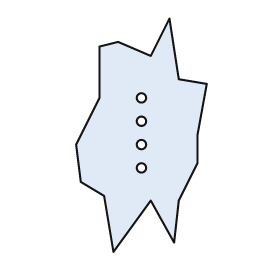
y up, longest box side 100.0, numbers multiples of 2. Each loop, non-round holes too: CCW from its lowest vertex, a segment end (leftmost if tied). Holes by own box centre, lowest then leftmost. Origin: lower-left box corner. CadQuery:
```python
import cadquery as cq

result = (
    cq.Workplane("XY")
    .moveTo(16.0, 0.0)
    .lineTo(32.0, 22.0)
    .lineTo(42.0, 4.0)
    .lineTo(44.0, 22.0)
    .lineTo(52.0, 38.0)
    .lineTo(52.0, 50.0)
    .lineTo(56.0, 72.0)
    .lineTo(44.0, 74.0)
    .lineTo(40.0, 100.0)
    .lineTo(32.0, 84.0)
    .lineTo(18.0, 90.0)
    .lineTo(10.0, 88.0)
    .lineTo(10.0, 66.0)
    .lineTo(0.0, 46.0)
    .lineTo(2.0, 30.0)
    .lineTo(12.0, 24.0)
    .close()
    .moveTo(28.0, 36.0)
    .circle(2.0)
    .moveTo(28.0, 46.0)
    .circle(2.0)
    .moveTo(28.0, 56.0)
    .circle(2.0)
    .moveTo(28.0, 66.0)
    .circle(2.0)
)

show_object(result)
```